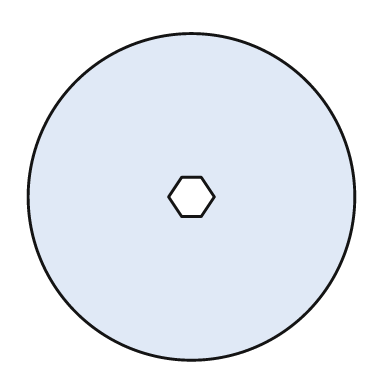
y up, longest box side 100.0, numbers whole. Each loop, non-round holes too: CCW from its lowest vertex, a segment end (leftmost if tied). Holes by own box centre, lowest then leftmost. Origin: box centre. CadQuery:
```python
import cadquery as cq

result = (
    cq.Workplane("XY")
    .moveTo(0.0, 0.0)
    .circle(50.0)
    .moveTo(-3.0, -6.0)
    .lineTo(3.0, -6.0)
    .lineTo(7.0, 0.0)
    .lineTo(3.0, 6.0)
    .lineTo(-3.0, 6.0)
    .lineTo(-7.0, 0.0)
    .close()
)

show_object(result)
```